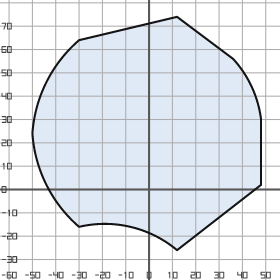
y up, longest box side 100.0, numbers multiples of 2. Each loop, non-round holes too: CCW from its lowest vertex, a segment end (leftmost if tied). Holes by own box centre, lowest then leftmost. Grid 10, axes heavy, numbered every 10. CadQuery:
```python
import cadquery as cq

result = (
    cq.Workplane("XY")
    .moveTo(12.0, -26.0)
    .lineTo(48.0, 2.0)
    .lineTo(48.0, 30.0)
    .threePointArc((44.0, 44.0), (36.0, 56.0))
    .lineTo(12.0, 74.0)
    .lineTo(-30.0, 64.0)
    .threePointArc((-44.0, 46.0), (-50.0, 24.0))
    .threePointArc((-44.0, 2.0), (-30.0, -16.0))
    .threePointArc((-8.0, -16.0), (12.0, -26.0))
    .close()
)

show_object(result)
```